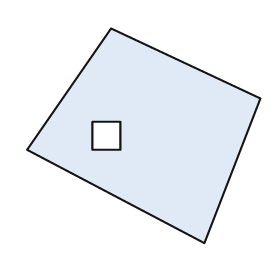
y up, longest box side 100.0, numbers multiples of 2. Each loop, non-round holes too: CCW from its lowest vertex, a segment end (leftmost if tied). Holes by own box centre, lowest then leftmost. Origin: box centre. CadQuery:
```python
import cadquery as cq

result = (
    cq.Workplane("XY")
    .moveTo(26.0, -46.0)
    .lineTo(50.0, 16.0)
    .lineTo(-14.0, 46.0)
    .lineTo(-50.0, -6.0)
    .close()
    .moveTo(-22.0, -6.0)
    .lineTo(-10.0, -6.0)
    .lineTo(-10.0, 6.0)
    .lineTo(-22.0, 6.0)
    .close()
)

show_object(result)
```